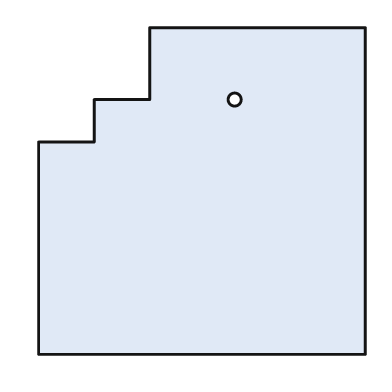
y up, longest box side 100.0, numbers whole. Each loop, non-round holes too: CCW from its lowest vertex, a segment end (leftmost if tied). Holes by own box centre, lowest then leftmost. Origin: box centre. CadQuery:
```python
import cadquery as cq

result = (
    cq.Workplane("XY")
    .moveTo(-50.0, -50.0)
    .lineTo(50.0, -50.0)
    .lineTo(50.0, 50.0)
    .lineTo(-16.0, 50.0)
    .lineTo(-16.0, 28.0)
    .lineTo(-33.0, 28.0)
    .lineTo(-33.0, 15.0)
    .lineTo(-50.0, 15.0)
    .close()
    .moveTo(10.0, 28.0)
    .circle(2.0)
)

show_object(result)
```